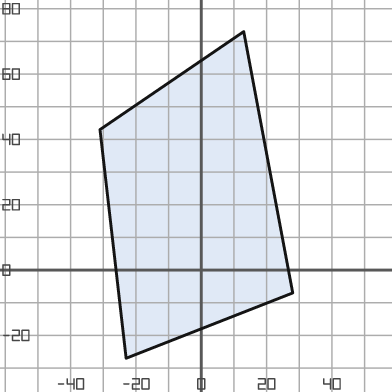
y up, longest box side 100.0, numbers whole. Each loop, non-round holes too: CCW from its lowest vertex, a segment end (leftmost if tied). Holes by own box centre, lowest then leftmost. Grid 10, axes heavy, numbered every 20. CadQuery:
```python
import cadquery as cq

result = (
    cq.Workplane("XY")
    .moveTo(-23.0, -27.0)
    .lineTo(28.0, -7.0)
    .lineTo(13.0, 73.0)
    .lineTo(-31.0, 43.0)
    .close()
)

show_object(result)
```